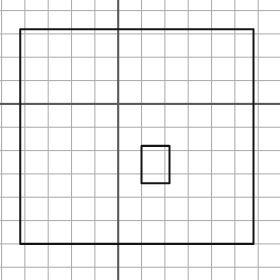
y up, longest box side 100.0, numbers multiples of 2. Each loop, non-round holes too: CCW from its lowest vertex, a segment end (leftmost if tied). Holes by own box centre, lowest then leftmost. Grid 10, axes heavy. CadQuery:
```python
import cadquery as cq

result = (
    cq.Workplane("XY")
    .moveTo(-42.0, -60.0)
    .lineTo(58.0, -60.0)
    .lineTo(58.0, 32.0)
    .lineTo(-42.0, 32.0)
    .close()
    .moveTo(10.0, -34.0)
    .lineTo(22.0, -34.0)
    .lineTo(22.0, -18.0)
    .lineTo(10.0, -18.0)
    .close()
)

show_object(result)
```